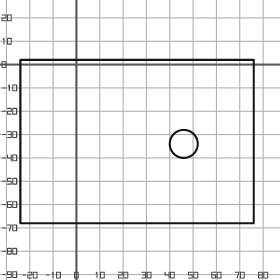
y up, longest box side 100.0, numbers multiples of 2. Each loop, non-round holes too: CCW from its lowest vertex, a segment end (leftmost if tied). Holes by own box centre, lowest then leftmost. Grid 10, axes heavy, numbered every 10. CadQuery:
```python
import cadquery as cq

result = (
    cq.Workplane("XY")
    .moveTo(-24.0, -68.0)
    .lineTo(76.0, -68.0)
    .lineTo(76.0, 2.0)
    .lineTo(-24.0, 2.0)
    .close()
    .moveTo(46.0, -34.0)
    .circle(6.0)
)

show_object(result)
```